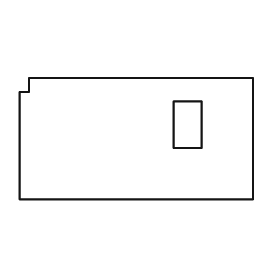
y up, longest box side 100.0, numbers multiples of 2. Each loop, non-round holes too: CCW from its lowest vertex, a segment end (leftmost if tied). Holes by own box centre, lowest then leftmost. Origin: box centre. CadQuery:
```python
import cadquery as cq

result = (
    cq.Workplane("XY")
    .moveTo(-50.0, -26.0)
    .lineTo(50.0, -26.0)
    .lineTo(50.0, 26.0)
    .lineTo(-46.0, 26.0)
    .lineTo(-46.0, 20.0)
    .lineTo(-50.0, 20.0)
    .close()
    .moveTo(16.0, -4.0)
    .lineTo(28.0, -4.0)
    .lineTo(28.0, 16.0)
    .lineTo(16.0, 16.0)
    .close()
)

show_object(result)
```